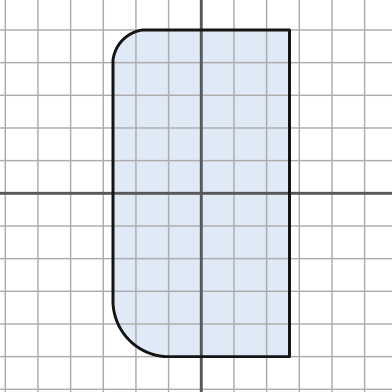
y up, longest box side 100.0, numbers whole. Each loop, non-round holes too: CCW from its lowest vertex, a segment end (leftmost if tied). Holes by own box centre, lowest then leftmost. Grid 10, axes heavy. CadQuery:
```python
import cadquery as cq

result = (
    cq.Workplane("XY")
    .moveTo(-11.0, -50.0)
    .lineTo(27.0, -50.0)
    .lineTo(27.0, 50.0)
    .lineTo(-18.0, 50.0)
    .threePointArc((-24.0, 47.0), (-27.0, 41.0))
    .lineTo(-27.0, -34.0)
    .threePointArc((-22.0, -45.0), (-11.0, -50.0))
    .close()
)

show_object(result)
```